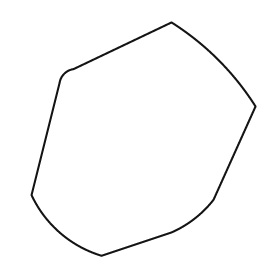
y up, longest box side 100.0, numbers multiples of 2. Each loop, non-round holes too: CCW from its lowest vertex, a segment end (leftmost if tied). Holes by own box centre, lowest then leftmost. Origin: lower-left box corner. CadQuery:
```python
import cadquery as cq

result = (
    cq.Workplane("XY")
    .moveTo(30.0, 0.0)
    .lineTo(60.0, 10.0)
    .threePointArc((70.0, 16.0), (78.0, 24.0))
    .lineTo(96.0, 64.0)
    .threePointArc((80.0, 84.0), (60.0, 100.0))
    .lineTo(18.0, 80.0)
    .threePointArc((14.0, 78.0), (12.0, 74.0))
    .lineTo(0.0, 26.0)
    .threePointArc((12.0, 10.0), (30.0, 0.0))
    .close()
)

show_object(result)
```